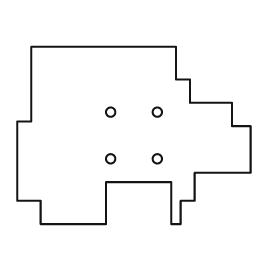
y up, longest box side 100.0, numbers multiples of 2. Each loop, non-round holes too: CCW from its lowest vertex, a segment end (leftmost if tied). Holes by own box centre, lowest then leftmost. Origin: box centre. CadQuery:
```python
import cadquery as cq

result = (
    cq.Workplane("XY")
    .moveTo(-40.0, -38.0)
    .lineTo(-12.0, -38.0)
    .lineTo(-12.0, -20.0)
    .lineTo(16.0, -20.0)
    .lineTo(16.0, -38.0)
    .lineTo(20.0, -38.0)
    .lineTo(20.0, -28.0)
    .lineTo(26.0, -28.0)
    .lineTo(26.0, -16.0)
    .lineTo(50.0, -16.0)
    .lineTo(50.0, 4.0)
    .lineTo(42.0, 4.0)
    .lineTo(42.0, 14.0)
    .lineTo(24.0, 14.0)
    .lineTo(24.0, 24.0)
    .lineTo(18.0, 24.0)
    .lineTo(18.0, 38.0)
    .lineTo(-44.0, 38.0)
    .lineTo(-44.0, 6.0)
    .lineTo(-50.0, 6.0)
    .lineTo(-50.0, -28.0)
    .lineTo(-40.0, -28.0)
    .close()
    .moveTo(-10.0, -10.0)
    .circle(2.0)
    .moveTo(10.0, -10.0)
    .circle(2.0)
    .moveTo(-10.0, 10.0)
    .circle(2.0)
    .moveTo(10.0, 10.0)
    .circle(2.0)
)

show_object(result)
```